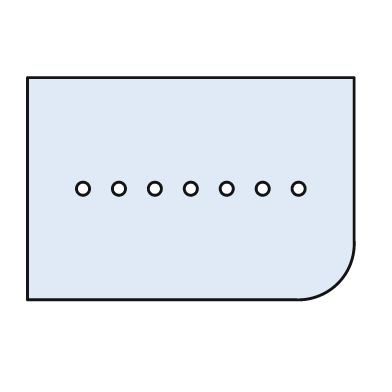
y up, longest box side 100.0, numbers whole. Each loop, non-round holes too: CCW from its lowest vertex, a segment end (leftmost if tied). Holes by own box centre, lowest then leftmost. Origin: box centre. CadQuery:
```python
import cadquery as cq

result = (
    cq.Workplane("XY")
    .moveTo(-50.0, -34.0)
    .lineTo(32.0, -34.0)
    .threePointArc((45.0, -29.0), (50.0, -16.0))
    .lineTo(50.0, 34.0)
    .lineTo(-50.0, 34.0)
    .close()
    .moveTo(-33.0, 0.0)
    .circle(2.0)
    .moveTo(-22.0, 0.0)
    .circle(2.0)
    .moveTo(-11.0, 0.0)
    .circle(2.0)
    .moveTo(0.0, 0.0)
    .circle(2.0)
    .moveTo(11.0, 0.0)
    .circle(2.0)
    .moveTo(22.0, 0.0)
    .circle(2.0)
    .moveTo(33.0, 0.0)
    .circle(2.0)
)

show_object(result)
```